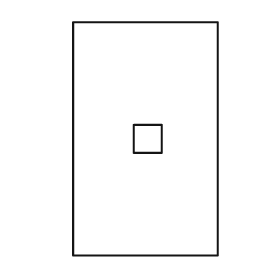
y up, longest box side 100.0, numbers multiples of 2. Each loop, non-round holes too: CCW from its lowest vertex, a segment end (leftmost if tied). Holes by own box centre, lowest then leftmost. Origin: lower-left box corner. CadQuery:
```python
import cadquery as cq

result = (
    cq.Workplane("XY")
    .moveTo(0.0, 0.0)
    .lineTo(62.0, 0.0)
    .lineTo(62.0, 100.0)
    .lineTo(0.0, 100.0)
    .close()
    .moveTo(26.0, 44.0)
    .lineTo(38.0, 44.0)
    .lineTo(38.0, 56.0)
    .lineTo(26.0, 56.0)
    .close()
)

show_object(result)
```